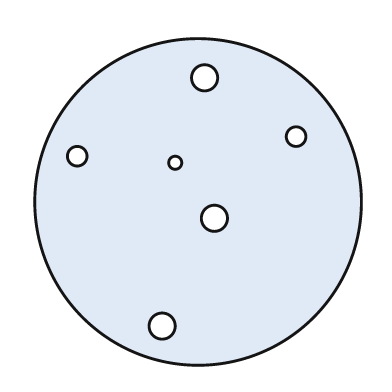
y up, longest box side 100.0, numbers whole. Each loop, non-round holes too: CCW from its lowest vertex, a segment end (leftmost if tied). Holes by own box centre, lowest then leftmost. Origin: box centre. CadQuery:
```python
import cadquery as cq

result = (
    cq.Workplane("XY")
    .moveTo(0.0, 0.0)
    .circle(50.0)
    .moveTo(-11.0, -38.0)
    .circle(4.0)
    .moveTo(5.0, -5.0)
    .circle(4.0)
    .moveTo(-7.0, 12.0)
    .circle(2.0)
    .moveTo(-37.0, 14.0)
    .circle(3.0)
    .moveTo(30.0, 20.0)
    .circle(3.0)
    .moveTo(2.0, 38.0)
    .circle(4.0)
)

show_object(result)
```